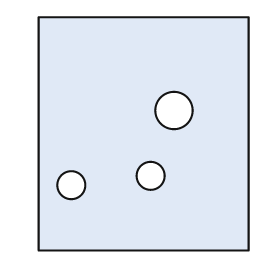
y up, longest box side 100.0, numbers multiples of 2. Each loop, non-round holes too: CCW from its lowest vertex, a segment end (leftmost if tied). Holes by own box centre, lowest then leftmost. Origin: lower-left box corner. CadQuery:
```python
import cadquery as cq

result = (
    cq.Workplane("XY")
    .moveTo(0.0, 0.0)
    .lineTo(90.0, 0.0)
    .lineTo(90.0, 100.0)
    .lineTo(0.0, 100.0)
    .close()
    .moveTo(14.0, 28.0)
    .circle(6.0)
    .moveTo(48.0, 32.0)
    .circle(6.0)
    .moveTo(58.0, 60.0)
    .circle(8.0)
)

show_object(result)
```